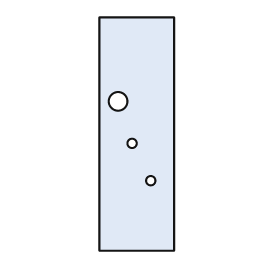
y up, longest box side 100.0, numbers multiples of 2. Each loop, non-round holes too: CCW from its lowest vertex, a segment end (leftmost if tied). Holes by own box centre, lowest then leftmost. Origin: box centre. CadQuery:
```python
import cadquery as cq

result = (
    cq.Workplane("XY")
    .moveTo(-16.0, -50.0)
    .lineTo(16.0, -50.0)
    .lineTo(16.0, 50.0)
    .lineTo(-16.0, 50.0)
    .close()
    .moveTo(6.0, -20.0)
    .circle(2.0)
    .moveTo(-2.0, -4.0)
    .circle(2.0)
    .moveTo(-8.0, 14.0)
    .circle(4.0)
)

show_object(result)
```